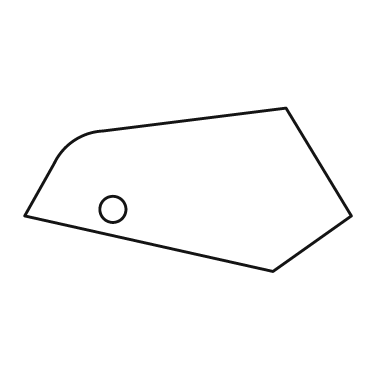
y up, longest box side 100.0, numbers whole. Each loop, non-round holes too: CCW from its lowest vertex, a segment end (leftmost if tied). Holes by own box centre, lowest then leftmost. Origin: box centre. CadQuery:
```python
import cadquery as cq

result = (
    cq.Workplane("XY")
    .moveTo(26.0, -25.0)
    .lineTo(50.0, -8.0)
    .lineTo(30.0, 25.0)
    .lineTo(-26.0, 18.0)
    .threePointArc((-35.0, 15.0), (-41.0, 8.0))
    .lineTo(-50.0, -8.0)
    .close()
    .moveTo(-23.0, -6.0)
    .circle(4.0)
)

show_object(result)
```